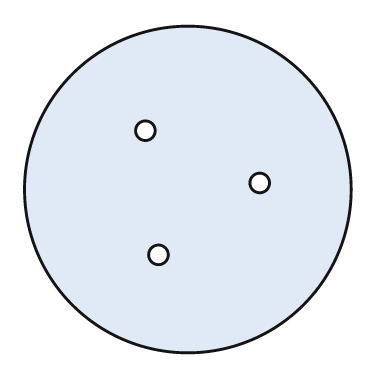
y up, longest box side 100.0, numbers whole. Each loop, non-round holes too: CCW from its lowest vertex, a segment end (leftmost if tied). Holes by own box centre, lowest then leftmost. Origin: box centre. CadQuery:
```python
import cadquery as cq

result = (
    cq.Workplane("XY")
    .moveTo(0.0, 0.0)
    .circle(50.0)
    .moveTo(-9.0, -20.0)
    .circle(3.0)
    .moveTo(22.0, 2.0)
    .circle(3.0)
    .moveTo(-13.0, 18.0)
    .circle(3.0)
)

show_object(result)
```